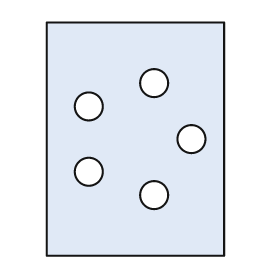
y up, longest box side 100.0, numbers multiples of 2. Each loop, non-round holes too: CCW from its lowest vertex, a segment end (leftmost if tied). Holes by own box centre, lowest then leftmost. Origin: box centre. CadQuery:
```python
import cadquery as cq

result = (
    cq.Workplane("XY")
    .moveTo(-38.0, -50.0)
    .lineTo(38.0, -50.0)
    .lineTo(38.0, 50.0)
    .lineTo(-38.0, 50.0)
    .close()
    .moveTo(8.0, -24.0)
    .circle(6.0)
    .moveTo(-20.0, -14.0)
    .circle(6.0)
    .moveTo(24.0, 0.0)
    .circle(6.0)
    .moveTo(-20.0, 14.0)
    .circle(6.0)
    .moveTo(8.0, 24.0)
    .circle(6.0)
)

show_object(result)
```